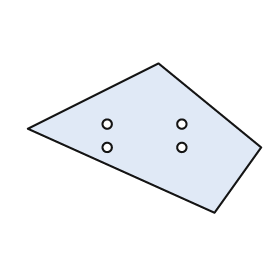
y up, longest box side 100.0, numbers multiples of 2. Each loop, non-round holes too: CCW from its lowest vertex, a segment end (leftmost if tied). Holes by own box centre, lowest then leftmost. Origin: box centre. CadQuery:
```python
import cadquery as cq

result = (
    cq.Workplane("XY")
    .moveTo(30.0, -32.0)
    .lineTo(50.0, -4.0)
    .lineTo(6.0, 32.0)
    .lineTo(-50.0, 4.0)
    .close()
    .moveTo(-16.0, -4.0)
    .circle(2.0)
    .moveTo(16.0, -4.0)
    .circle(2.0)
    .moveTo(-16.0, 6.0)
    .circle(2.0)
    .moveTo(16.0, 6.0)
    .circle(2.0)
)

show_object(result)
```